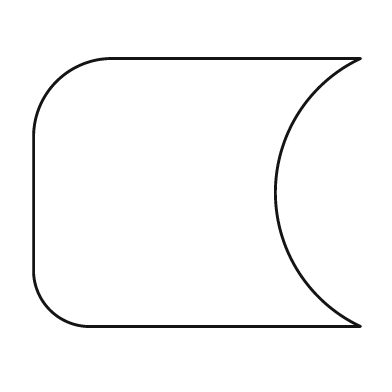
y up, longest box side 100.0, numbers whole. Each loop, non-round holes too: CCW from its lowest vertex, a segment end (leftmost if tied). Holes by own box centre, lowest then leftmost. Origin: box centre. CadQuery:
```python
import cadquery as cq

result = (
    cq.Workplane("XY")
    .moveTo(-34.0, -41.0)
    .lineTo(50.0, -41.0)
    .threePointArc((24.0, 0.0), (50.0, 41.0))
    .lineTo(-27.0, 41.0)
    .threePointArc((-43.0, 34.0), (-50.0, 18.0))
    .lineTo(-50.0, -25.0)
    .threePointArc((-45.0, -36.0), (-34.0, -41.0))
    .close()
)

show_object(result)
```